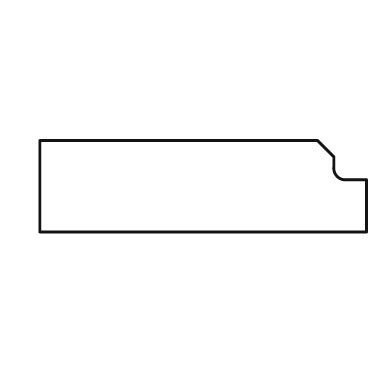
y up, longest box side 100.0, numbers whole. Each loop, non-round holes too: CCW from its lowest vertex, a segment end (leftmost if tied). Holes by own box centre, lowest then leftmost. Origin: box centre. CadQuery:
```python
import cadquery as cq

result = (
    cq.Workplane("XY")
    .moveTo(-50.0, -14.0)
    .lineTo(50.0, -14.0)
    .lineTo(50.0, 2.0)
    .lineTo(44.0, 2.0)
    .threePointArc((41.0, 3.0), (40.0, 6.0))
    .lineTo(40.0, 9.0)
    .lineTo(35.0, 14.0)
    .lineTo(-50.0, 14.0)
    .close()
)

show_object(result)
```